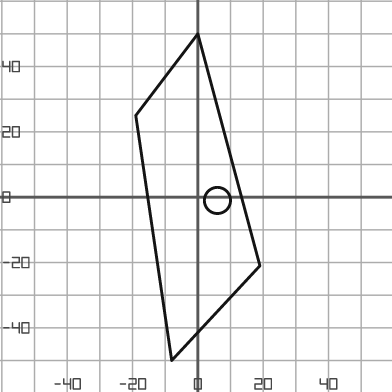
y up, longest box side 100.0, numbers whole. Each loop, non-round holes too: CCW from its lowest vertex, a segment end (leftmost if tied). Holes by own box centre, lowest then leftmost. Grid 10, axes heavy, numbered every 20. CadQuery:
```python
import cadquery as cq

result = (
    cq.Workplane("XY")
    .moveTo(-8.0, -50.0)
    .lineTo(19.0, -21.0)
    .lineTo(0.0, 50.0)
    .lineTo(-19.0, 25.0)
    .close()
    .moveTo(6.0, -1.0)
    .circle(4.0)
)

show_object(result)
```